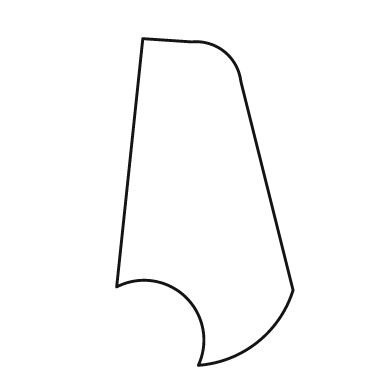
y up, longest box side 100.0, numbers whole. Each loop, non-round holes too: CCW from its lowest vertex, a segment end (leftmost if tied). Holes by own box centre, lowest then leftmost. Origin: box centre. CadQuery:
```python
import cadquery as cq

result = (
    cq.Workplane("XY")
    .moveTo(-2.0, -50.0)
    .threePointArc((16.0, -43.0), (27.0, -27.0))
    .lineTo(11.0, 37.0)
    .threePointArc((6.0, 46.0), (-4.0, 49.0))
    .lineTo(-19.0, 50.0)
    .lineTo(-27.0, -26.0)
    .threePointArc((-6.0, -29.0), (-2.0, -50.0))
    .close()
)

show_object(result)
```